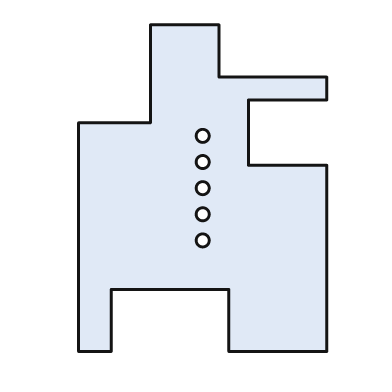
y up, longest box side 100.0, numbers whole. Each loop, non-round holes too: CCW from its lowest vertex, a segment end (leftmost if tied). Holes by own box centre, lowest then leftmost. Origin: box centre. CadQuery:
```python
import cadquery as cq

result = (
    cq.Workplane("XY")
    .moveTo(-38.0, -50.0)
    .lineTo(-28.0, -50.0)
    .lineTo(-28.0, -31.0)
    .lineTo(8.0, -31.0)
    .lineTo(8.0, -50.0)
    .lineTo(38.0, -50.0)
    .lineTo(38.0, 7.0)
    .lineTo(14.0, 7.0)
    .lineTo(14.0, 27.0)
    .lineTo(38.0, 27.0)
    .lineTo(38.0, 34.0)
    .lineTo(5.0, 34.0)
    .lineTo(5.0, 50.0)
    .lineTo(-16.0, 50.0)
    .lineTo(-16.0, 20.0)
    .lineTo(-38.0, 20.0)
    .close()
    .moveTo(0.0, -16.0)
    .circle(2.0)
    .moveTo(0.0, -8.0)
    .circle(2.0)
    .moveTo(0.0, 0.0)
    .circle(2.0)
    .moveTo(0.0, 8.0)
    .circle(2.0)
    .moveTo(0.0, 16.0)
    .circle(2.0)
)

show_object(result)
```